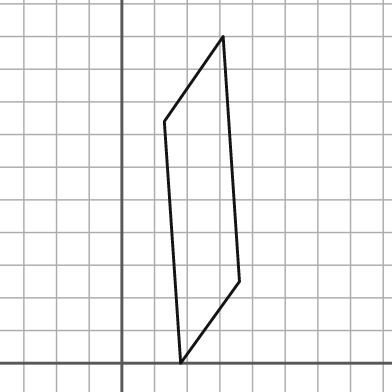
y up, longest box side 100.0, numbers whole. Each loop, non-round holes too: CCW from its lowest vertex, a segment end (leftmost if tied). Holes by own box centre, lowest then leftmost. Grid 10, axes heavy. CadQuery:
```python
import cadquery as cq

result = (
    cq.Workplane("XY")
    .moveTo(18.0, 0.0)
    .lineTo(36.0, 25.0)
    .lineTo(31.0, 100.0)
    .lineTo(13.0, 74.0)
    .close()
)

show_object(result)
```